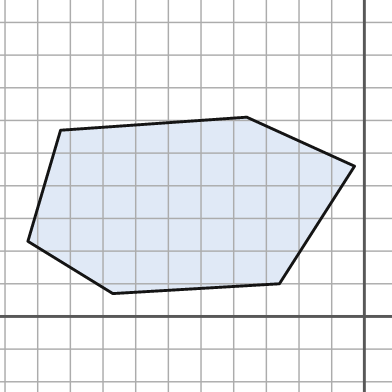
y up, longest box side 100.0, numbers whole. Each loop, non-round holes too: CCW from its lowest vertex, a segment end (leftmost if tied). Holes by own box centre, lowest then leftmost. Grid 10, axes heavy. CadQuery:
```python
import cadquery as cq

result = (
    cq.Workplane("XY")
    .moveTo(-77.0, 7.0)
    .lineTo(-26.0, 10.0)
    .lineTo(-3.0, 46.0)
    .lineTo(-36.0, 61.0)
    .lineTo(-93.0, 57.0)
    .lineTo(-103.0, 23.0)
    .close()
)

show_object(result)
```